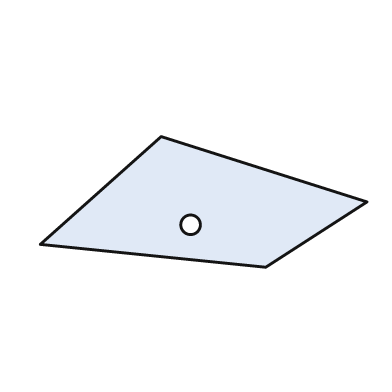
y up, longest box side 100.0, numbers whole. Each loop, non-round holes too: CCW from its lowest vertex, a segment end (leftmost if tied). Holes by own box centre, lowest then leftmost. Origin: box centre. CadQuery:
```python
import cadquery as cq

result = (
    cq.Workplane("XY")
    .moveTo(19.0, -20.0)
    .lineTo(50.0, 0.0)
    .lineTo(-13.0, 20.0)
    .lineTo(-50.0, -13.0)
    .close()
    .moveTo(-4.0, -7.0)
    .circle(3.0)
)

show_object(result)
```